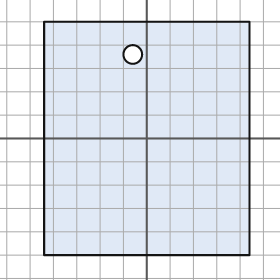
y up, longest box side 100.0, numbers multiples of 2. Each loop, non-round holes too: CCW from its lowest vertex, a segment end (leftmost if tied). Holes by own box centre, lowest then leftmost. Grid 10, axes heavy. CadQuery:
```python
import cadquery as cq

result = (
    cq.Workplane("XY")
    .moveTo(-44.0, -50.0)
    .lineTo(44.0, -50.0)
    .lineTo(44.0, 50.0)
    .lineTo(-44.0, 50.0)
    .close()
    .moveTo(-6.0, 36.0)
    .circle(4.0)
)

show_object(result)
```